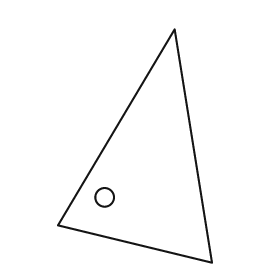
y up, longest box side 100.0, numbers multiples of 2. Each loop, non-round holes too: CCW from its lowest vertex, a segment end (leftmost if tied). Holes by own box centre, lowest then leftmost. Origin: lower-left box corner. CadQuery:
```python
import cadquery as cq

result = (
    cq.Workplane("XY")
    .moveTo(66.0, 0.0)
    .lineTo(50.0, 100.0)
    .lineTo(0.0, 16.0)
    .close()
    .moveTo(20.0, 28.0)
    .circle(4.0)
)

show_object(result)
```